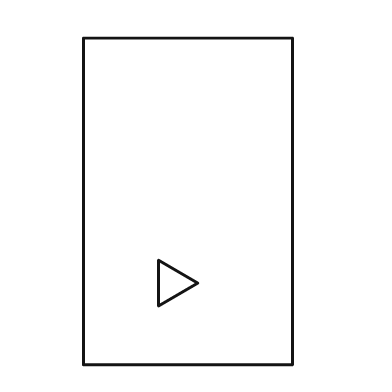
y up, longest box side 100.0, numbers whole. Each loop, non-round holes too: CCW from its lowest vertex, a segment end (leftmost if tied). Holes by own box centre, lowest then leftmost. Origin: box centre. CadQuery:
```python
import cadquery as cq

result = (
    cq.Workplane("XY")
    .moveTo(-32.0, -50.0)
    .lineTo(32.0, -50.0)
    .lineTo(32.0, 50.0)
    .lineTo(-32.0, 50.0)
    .close()
    .moveTo(-9.0, -32.0)
    .lineTo(3.0, -25.0)
    .lineTo(-9.0, -18.0)
    .close()
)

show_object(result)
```